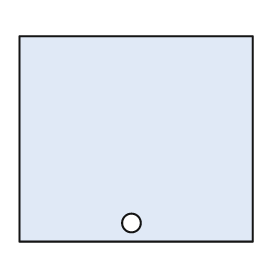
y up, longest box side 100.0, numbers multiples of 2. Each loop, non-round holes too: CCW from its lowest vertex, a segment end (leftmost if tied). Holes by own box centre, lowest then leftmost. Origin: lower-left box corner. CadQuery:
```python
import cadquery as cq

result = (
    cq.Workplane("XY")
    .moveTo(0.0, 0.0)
    .lineTo(100.0, 0.0)
    .lineTo(100.0, 88.0)
    .lineTo(0.0, 88.0)
    .close()
    .moveTo(48.0, 8.0)
    .circle(4.0)
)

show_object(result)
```